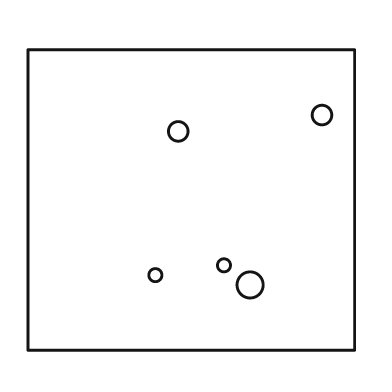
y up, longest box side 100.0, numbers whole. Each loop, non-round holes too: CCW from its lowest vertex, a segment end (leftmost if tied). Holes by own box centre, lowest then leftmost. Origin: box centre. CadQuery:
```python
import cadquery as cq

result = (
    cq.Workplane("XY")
    .moveTo(-50.0, -46.0)
    .lineTo(50.0, -46.0)
    .lineTo(50.0, 46.0)
    .lineTo(-50.0, 46.0)
    .close()
    .moveTo(18.0, -26.0)
    .circle(4.0)
    .moveTo(-11.0, -23.0)
    .circle(2.0)
    .moveTo(10.0, -20.0)
    .circle(2.0)
    .moveTo(-4.0, 21.0)
    .circle(3.0)
    .moveTo(40.0, 26.0)
    .circle(3.0)
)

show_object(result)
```